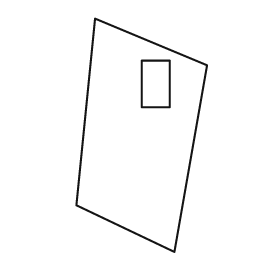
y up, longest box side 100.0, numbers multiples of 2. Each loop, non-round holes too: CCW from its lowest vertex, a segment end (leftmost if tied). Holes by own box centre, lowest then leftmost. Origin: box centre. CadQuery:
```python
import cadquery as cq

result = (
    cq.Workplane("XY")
    .moveTo(14.0, -50.0)
    .lineTo(28.0, 30.0)
    .lineTo(-20.0, 50.0)
    .lineTo(-28.0, -30.0)
    .close()
    .moveTo(0.0, 12.0)
    .lineTo(12.0, 12.0)
    .lineTo(12.0, 32.0)
    .lineTo(0.0, 32.0)
    .close()
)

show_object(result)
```